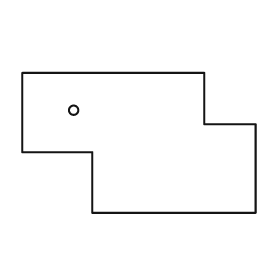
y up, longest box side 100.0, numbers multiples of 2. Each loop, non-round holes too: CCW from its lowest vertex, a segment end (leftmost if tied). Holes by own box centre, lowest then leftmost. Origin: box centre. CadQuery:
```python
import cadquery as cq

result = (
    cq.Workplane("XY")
    .moveTo(-20.0, -30.0)
    .lineTo(50.0, -30.0)
    .lineTo(50.0, 8.0)
    .lineTo(28.0, 8.0)
    .lineTo(28.0, 30.0)
    .lineTo(-50.0, 30.0)
    .lineTo(-50.0, -4.0)
    .lineTo(-20.0, -4.0)
    .close()
    .moveTo(-28.0, 14.0)
    .circle(2.0)
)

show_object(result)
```